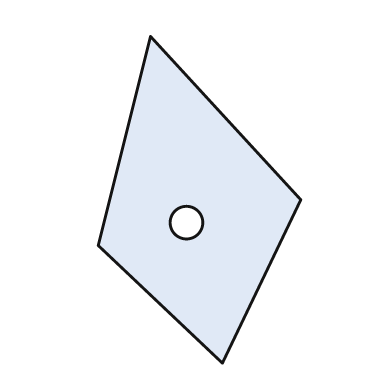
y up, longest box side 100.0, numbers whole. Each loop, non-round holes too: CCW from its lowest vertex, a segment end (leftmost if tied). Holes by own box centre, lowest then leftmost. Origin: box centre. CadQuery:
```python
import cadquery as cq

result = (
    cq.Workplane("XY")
    .moveTo(7.0, -50.0)
    .lineTo(31.0, 0.0)
    .lineTo(-15.0, 50.0)
    .lineTo(-31.0, -14.0)
    .close()
    .moveTo(-4.0, -7.0)
    .circle(5.0)
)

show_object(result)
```